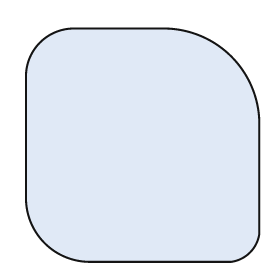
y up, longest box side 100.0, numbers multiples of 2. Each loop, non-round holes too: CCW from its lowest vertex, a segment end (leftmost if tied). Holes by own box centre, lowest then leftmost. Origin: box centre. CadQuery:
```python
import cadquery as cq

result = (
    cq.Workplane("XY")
    .moveTo(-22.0, -50.0)
    .lineTo(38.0, -50.0)
    .threePointArc((46.0, -46.0), (50.0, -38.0))
    .lineTo(50.0, 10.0)
    .threePointArc((38.0, 38.0), (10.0, 50.0))
    .lineTo(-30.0, 50.0)
    .threePointArc((-44.0, 44.0), (-50.0, 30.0))
    .lineTo(-50.0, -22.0)
    .threePointArc((-42.0, -42.0), (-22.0, -50.0))
    .close()
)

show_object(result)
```